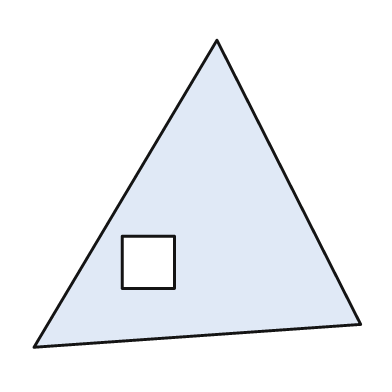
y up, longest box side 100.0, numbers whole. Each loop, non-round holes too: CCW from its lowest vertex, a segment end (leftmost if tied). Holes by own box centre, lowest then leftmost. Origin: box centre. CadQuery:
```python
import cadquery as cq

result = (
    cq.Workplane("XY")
    .moveTo(-50.0, -47.0)
    .lineTo(50.0, -40.0)
    .lineTo(6.0, 47.0)
    .close()
    .moveTo(-23.0, -29.0)
    .lineTo(-7.0, -29.0)
    .lineTo(-7.0, -13.0)
    .lineTo(-23.0, -13.0)
    .close()
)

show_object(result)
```